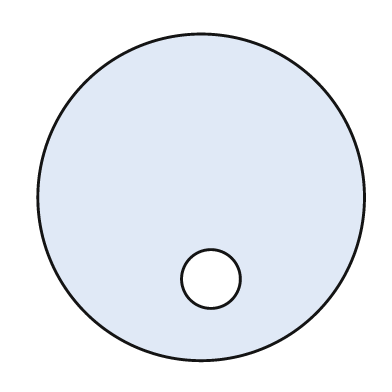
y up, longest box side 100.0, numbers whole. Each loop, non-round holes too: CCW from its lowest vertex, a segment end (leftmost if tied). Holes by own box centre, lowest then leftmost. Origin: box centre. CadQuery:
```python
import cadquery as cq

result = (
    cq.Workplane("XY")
    .moveTo(0.0, 0.0)
    .circle(50.0)
    .moveTo(3.0, -25.0)
    .circle(9.0)
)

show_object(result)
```